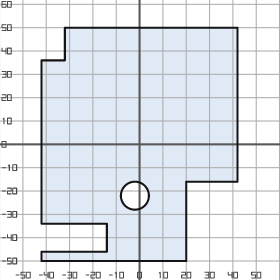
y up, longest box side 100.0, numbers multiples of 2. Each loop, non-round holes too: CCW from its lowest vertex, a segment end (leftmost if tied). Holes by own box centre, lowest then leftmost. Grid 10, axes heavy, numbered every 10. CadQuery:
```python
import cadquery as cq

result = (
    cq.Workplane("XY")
    .moveTo(-42.0, -50.0)
    .lineTo(20.0, -50.0)
    .lineTo(20.0, -16.0)
    .lineTo(42.0, -16.0)
    .lineTo(42.0, 50.0)
    .lineTo(-32.0, 50.0)
    .lineTo(-32.0, 36.0)
    .lineTo(-42.0, 36.0)
    .lineTo(-42.0, -34.0)
    .lineTo(-14.0, -34.0)
    .lineTo(-14.0, -46.0)
    .lineTo(-42.0, -46.0)
    .close()
    .moveTo(-2.0, -22.0)
    .circle(6.0)
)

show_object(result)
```